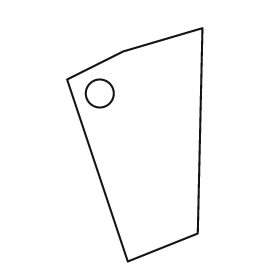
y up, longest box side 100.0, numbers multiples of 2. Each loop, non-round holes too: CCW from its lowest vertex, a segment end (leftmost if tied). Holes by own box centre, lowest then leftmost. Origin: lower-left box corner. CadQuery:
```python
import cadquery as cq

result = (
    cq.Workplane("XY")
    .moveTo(26.0, 0.0)
    .lineTo(56.0, 12.0)
    .lineTo(58.0, 100.0)
    .lineTo(24.0, 90.0)
    .lineTo(0.0, 78.0)
    .close()
    .moveTo(14.0, 72.0)
    .circle(6.0)
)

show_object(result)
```